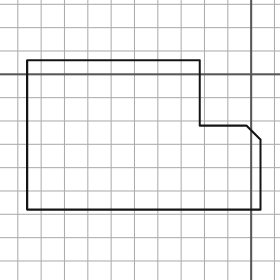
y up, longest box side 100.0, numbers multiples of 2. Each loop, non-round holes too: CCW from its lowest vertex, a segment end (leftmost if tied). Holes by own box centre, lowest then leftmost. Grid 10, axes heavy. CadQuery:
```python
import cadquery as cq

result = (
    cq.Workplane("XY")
    .moveTo(-96.0, -58.0)
    .lineTo(4.0, -58.0)
    .lineTo(4.0, -28.0)
    .lineTo(-2.0, -22.0)
    .lineTo(-22.0, -22.0)
    .lineTo(-22.0, 6.0)
    .lineTo(-96.0, 6.0)
    .close()
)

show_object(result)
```